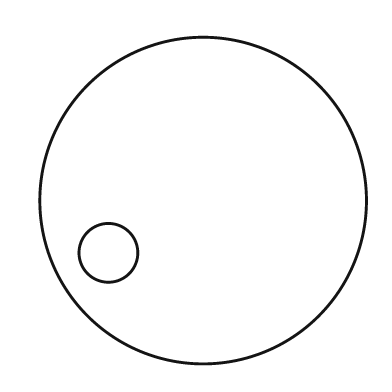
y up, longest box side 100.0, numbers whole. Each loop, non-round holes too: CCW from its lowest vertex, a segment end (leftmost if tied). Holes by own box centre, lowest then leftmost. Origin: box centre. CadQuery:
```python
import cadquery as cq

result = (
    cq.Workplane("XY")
    .moveTo(0.0, 0.0)
    .circle(50.0)
    .moveTo(-29.0, -16.0)
    .circle(9.0)
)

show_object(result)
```